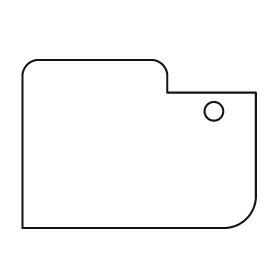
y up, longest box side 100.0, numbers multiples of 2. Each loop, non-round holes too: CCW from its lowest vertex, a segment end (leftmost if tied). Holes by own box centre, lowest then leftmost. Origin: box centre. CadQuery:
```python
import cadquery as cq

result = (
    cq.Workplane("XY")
    .moveTo(-50.0, -36.0)
    .lineTo(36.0, -36.0)
    .threePointArc((46.0, -32.0), (50.0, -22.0))
    .lineTo(50.0, 22.0)
    .lineTo(12.0, 22.0)
    .lineTo(12.0, 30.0)
    .threePointArc((10.0, 34.0), (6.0, 36.0))
    .lineTo(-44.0, 36.0)
    .threePointArc((-48.0, 34.0), (-50.0, 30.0))
    .close()
    .moveTo(32.0, 14.0)
    .circle(4.0)
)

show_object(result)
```